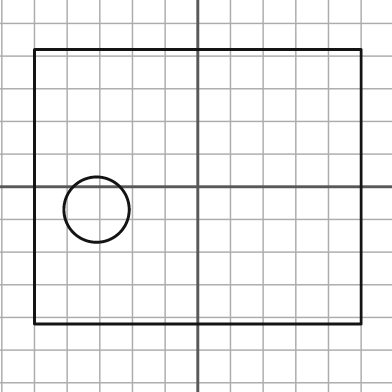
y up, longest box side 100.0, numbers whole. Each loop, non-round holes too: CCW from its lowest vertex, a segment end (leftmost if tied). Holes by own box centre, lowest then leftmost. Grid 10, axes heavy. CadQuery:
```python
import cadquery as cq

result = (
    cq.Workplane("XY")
    .moveTo(-50.0, -42.0)
    .lineTo(50.0, -42.0)
    .lineTo(50.0, 42.0)
    .lineTo(-50.0, 42.0)
    .close()
    .moveTo(-31.0, -7.0)
    .circle(10.0)
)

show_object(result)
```